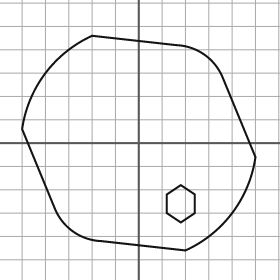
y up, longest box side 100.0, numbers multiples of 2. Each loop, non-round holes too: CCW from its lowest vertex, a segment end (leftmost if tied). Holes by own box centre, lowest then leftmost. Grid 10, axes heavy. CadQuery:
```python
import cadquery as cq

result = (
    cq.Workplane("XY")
    .moveTo(20.0, -46.0)
    .threePointArc((40.0, -30.0), (50.0, -6.0))
    .lineTo(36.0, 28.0)
    .threePointArc((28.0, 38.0), (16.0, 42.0))
    .lineTo(-20.0, 46.0)
    .threePointArc((-40.0, 30.0), (-50.0, 6.0))
    .lineTo(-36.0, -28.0)
    .threePointArc((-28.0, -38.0), (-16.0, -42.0))
    .close()
    .moveTo(18.0, -34.0)
    .lineTo(24.0, -30.0)
    .lineTo(24.0, -22.0)
    .lineTo(18.0, -18.0)
    .lineTo(12.0, -22.0)
    .lineTo(12.0, -30.0)
    .close()
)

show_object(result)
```